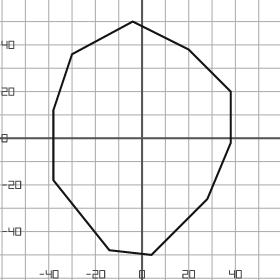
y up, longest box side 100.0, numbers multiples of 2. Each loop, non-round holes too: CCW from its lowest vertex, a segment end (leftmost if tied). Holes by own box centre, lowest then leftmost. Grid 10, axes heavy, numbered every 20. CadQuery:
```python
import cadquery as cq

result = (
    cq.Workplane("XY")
    .moveTo(4.0, -50.0)
    .lineTo(28.0, -26.0)
    .lineTo(38.0, -2.0)
    .lineTo(38.0, 20.0)
    .lineTo(20.0, 38.0)
    .lineTo(-4.0, 50.0)
    .lineTo(-30.0, 36.0)
    .lineTo(-38.0, 12.0)
    .lineTo(-38.0, -18.0)
    .lineTo(-14.0, -48.0)
    .close()
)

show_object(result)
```